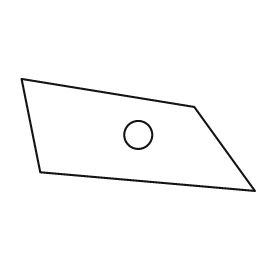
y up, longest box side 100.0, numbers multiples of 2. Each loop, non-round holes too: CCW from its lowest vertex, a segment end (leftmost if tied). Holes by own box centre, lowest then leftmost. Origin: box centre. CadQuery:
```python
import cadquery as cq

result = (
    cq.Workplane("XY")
    .moveTo(50.0, -24.0)
    .lineTo(24.0, 12.0)
    .lineTo(-50.0, 24.0)
    .lineTo(-42.0, -16.0)
    .close()
    .moveTo(0.0, 0.0)
    .circle(6.0)
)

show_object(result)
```